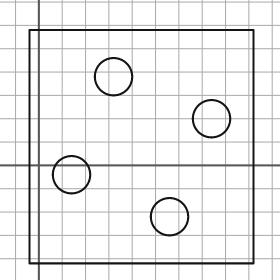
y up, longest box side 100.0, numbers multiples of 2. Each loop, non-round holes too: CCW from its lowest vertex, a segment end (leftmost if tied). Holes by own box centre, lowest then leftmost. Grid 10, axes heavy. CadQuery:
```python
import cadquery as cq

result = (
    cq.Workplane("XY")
    .moveTo(-4.0, -42.0)
    .lineTo(92.0, -42.0)
    .lineTo(92.0, 58.0)
    .lineTo(-4.0, 58.0)
    .close()
    .moveTo(56.0, -22.0)
    .circle(8.0)
    .moveTo(14.0, -4.0)
    .circle(8.0)
    .moveTo(74.0, 20.0)
    .circle(8.0)
    .moveTo(32.0, 38.0)
    .circle(8.0)
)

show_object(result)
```